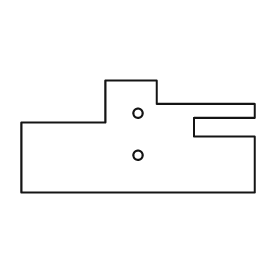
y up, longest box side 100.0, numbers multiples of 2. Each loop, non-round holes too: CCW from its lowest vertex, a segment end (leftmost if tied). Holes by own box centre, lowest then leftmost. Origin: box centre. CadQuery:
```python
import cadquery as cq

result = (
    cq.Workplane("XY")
    .moveTo(-50.0, -24.0)
    .lineTo(50.0, -24.0)
    .lineTo(50.0, 0.0)
    .lineTo(24.0, 0.0)
    .lineTo(24.0, 8.0)
    .lineTo(50.0, 8.0)
    .lineTo(50.0, 14.0)
    .lineTo(8.0, 14.0)
    .lineTo(8.0, 24.0)
    .lineTo(-14.0, 24.0)
    .lineTo(-14.0, 6.0)
    .lineTo(-50.0, 6.0)
    .close()
    .moveTo(0.0, -8.0)
    .circle(2.0)
    .moveTo(0.0, 10.0)
    .circle(2.0)
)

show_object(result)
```